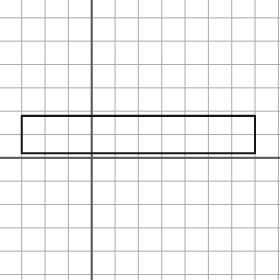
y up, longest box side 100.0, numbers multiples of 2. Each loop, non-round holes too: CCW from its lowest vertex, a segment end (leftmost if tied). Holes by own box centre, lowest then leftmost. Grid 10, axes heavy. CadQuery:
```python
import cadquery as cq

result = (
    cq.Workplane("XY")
    .moveTo(-30.0, 2.0)
    .lineTo(70.0, 2.0)
    .lineTo(70.0, 18.0)
    .lineTo(-30.0, 18.0)
    .close()
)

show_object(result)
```